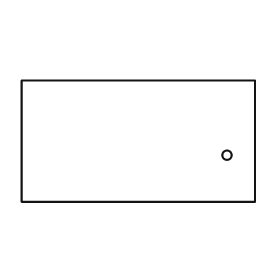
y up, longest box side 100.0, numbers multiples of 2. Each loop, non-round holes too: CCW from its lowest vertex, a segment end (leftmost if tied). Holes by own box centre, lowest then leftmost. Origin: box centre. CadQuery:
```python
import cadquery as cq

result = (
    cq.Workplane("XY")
    .moveTo(-50.0, -26.0)
    .lineTo(50.0, -26.0)
    .lineTo(50.0, 26.0)
    .lineTo(-50.0, 26.0)
    .close()
    .moveTo(38.0, -6.0)
    .circle(2.0)
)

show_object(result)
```